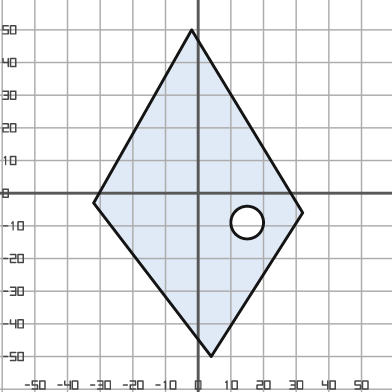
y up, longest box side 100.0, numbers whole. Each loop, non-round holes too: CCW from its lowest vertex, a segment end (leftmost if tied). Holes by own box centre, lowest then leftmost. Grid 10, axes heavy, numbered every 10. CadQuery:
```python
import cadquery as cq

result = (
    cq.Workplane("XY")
    .moveTo(4.0, -50.0)
    .lineTo(32.0, -6.0)
    .lineTo(-2.0, 50.0)
    .lineTo(-32.0, -3.0)
    .close()
    .moveTo(15.0, -9.0)
    .circle(5.0)
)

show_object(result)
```